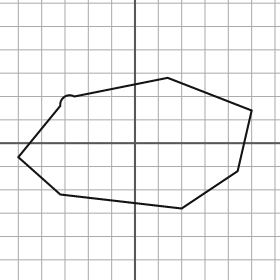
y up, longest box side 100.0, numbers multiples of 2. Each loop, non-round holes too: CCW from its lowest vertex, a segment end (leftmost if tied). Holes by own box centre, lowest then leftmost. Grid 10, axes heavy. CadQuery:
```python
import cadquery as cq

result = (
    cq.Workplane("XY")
    .moveTo(20.0, -28.0)
    .lineTo(44.0, -12.0)
    .lineTo(50.0, 14.0)
    .lineTo(14.0, 28.0)
    .lineTo(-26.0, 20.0)
    .threePointArc((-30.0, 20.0), (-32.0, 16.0))
    .lineTo(-50.0, -6.0)
    .lineTo(-32.0, -22.0)
    .close()
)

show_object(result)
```